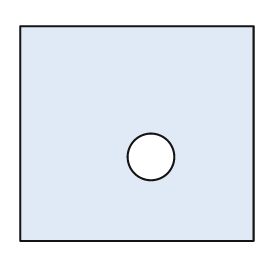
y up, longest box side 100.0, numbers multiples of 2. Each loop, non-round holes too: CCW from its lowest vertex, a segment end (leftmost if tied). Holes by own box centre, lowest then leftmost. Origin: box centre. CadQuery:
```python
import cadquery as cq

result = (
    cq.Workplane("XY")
    .moveTo(-50.0, -46.0)
    .lineTo(50.0, -46.0)
    .lineTo(50.0, 46.0)
    .lineTo(-50.0, 46.0)
    .close()
    .moveTo(6.0, -10.0)
    .circle(10.0)
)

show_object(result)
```